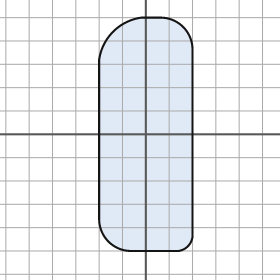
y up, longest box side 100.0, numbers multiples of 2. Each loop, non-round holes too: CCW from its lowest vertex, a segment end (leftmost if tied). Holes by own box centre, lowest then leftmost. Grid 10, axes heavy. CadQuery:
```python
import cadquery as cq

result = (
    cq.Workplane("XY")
    .moveTo(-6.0, -50.0)
    .lineTo(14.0, -50.0)
    .threePointArc((18.0, -48.0), (20.0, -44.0))
    .lineTo(20.0, 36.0)
    .threePointArc((16.0, 46.0), (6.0, 50.0))
    .lineTo(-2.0, 50.0)
    .threePointArc((-14.0, 44.0), (-20.0, 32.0))
    .lineTo(-20.0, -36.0)
    .threePointArc((-16.0, -46.0), (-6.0, -50.0))
    .close()
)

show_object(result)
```